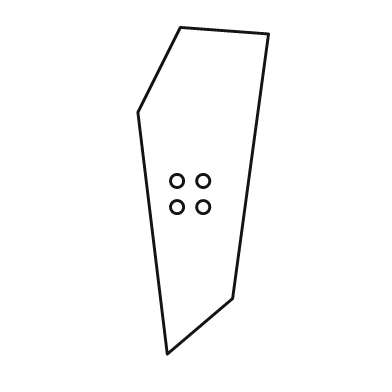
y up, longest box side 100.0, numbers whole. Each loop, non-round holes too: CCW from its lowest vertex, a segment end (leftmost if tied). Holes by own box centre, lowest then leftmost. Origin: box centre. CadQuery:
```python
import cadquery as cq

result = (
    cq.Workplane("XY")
    .moveTo(-11.0, -50.0)
    .lineTo(9.0, -33.0)
    .lineTo(20.0, 48.0)
    .lineTo(-7.0, 50.0)
    .lineTo(-20.0, 24.0)
    .close()
    .moveTo(-8.0, -5.0)
    .circle(2.0)
    .moveTo(0.0, -5.0)
    .circle(2.0)
    .moveTo(-8.0, 3.0)
    .circle(2.0)
    .moveTo(0.0, 3.0)
    .circle(2.0)
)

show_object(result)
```